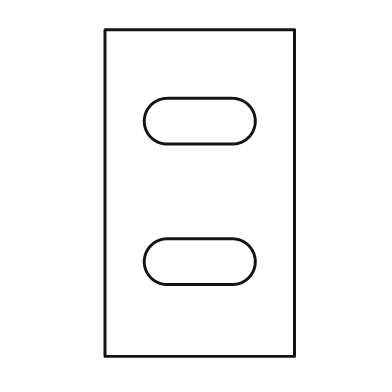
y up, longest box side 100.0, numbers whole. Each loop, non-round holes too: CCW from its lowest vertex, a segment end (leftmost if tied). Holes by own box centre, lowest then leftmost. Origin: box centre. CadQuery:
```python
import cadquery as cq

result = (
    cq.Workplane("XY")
    .moveTo(-29.0, -50.0)
    .lineTo(29.0, -50.0)
    .lineTo(29.0, 50.0)
    .lineTo(-29.0, 50.0)
    .close()
    .moveTo(-10.0, -28.0)
    .lineTo(10.0, -28.0)
    .threePointArc((17.0, -21.0), (10.0, -14.0))
    .lineTo(-10.0, -14.0)
    .threePointArc((-17.0, -21.0), (-10.0, -28.0))
    .close()
    .moveTo(-10.0, 15.0)
    .lineTo(10.0, 15.0)
    .threePointArc((17.0, 22.0), (10.0, 29.0))
    .lineTo(-10.0, 29.0)
    .threePointArc((-17.0, 22.0), (-10.0, 15.0))
    .close()
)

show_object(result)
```